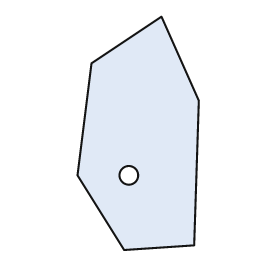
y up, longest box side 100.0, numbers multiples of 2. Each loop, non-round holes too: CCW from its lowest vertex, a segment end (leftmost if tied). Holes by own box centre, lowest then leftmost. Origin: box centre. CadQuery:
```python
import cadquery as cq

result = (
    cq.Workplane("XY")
    .moveTo(-6.0, -50.0)
    .lineTo(24.0, -48.0)
    .lineTo(26.0, 14.0)
    .lineTo(10.0, 50.0)
    .lineTo(-20.0, 30.0)
    .lineTo(-26.0, -18.0)
    .close()
    .moveTo(-4.0, -18.0)
    .circle(4.0)
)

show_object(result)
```